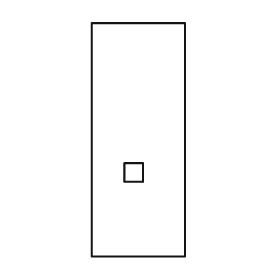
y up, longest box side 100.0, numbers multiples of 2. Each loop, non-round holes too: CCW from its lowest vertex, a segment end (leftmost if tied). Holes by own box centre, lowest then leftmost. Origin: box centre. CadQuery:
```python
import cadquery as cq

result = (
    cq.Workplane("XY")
    .moveTo(-20.0, -50.0)
    .lineTo(20.0, -50.0)
    .lineTo(20.0, 50.0)
    .lineTo(-20.0, 50.0)
    .close()
    .moveTo(-6.0, -18.0)
    .lineTo(2.0, -18.0)
    .lineTo(2.0, -10.0)
    .lineTo(-6.0, -10.0)
    .close()
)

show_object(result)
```